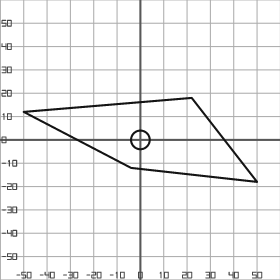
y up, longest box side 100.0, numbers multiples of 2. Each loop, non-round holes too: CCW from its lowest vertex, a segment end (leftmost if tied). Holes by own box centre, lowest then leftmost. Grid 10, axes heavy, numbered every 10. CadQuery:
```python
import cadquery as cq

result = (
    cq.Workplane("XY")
    .moveTo(50.0, -18.0)
    .lineTo(22.0, 18.0)
    .lineTo(-50.0, 12.0)
    .lineTo(-4.0, -12.0)
    .close()
    .moveTo(0.0, 0.0)
    .circle(4.0)
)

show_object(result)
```